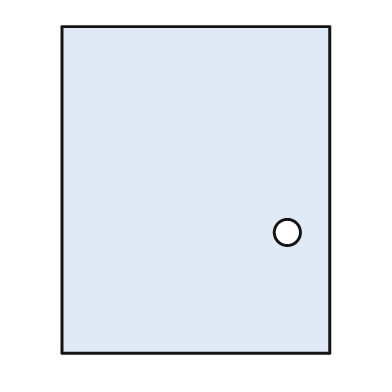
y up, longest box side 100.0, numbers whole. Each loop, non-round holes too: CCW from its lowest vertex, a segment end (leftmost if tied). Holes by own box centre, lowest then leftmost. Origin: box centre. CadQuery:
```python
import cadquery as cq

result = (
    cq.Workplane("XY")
    .moveTo(-41.0, -50.0)
    .lineTo(41.0, -50.0)
    .lineTo(41.0, 50.0)
    .lineTo(-41.0, 50.0)
    .close()
    .moveTo(28.0, -13.0)
    .circle(4.0)
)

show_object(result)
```